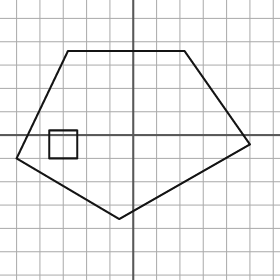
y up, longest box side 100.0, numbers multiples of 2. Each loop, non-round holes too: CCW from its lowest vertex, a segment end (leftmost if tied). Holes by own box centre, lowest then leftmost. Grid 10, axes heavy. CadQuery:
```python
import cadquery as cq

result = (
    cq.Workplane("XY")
    .moveTo(-6.0, -36.0)
    .lineTo(50.0, -4.0)
    .lineTo(22.0, 36.0)
    .lineTo(-28.0, 36.0)
    .lineTo(-50.0, -10.0)
    .close()
    .moveTo(-36.0, -10.0)
    .lineTo(-24.0, -10.0)
    .lineTo(-24.0, 2.0)
    .lineTo(-36.0, 2.0)
    .close()
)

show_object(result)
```